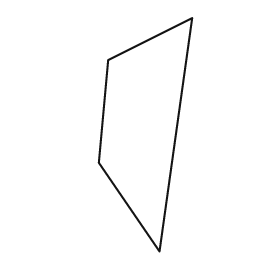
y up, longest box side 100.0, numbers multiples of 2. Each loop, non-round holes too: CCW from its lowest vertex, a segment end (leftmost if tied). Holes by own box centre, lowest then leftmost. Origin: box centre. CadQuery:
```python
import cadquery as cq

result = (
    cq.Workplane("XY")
    .moveTo(6.0, -50.0)
    .lineTo(20.0, 50.0)
    .lineTo(-16.0, 32.0)
    .lineTo(-20.0, -12.0)
    .close()
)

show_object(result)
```